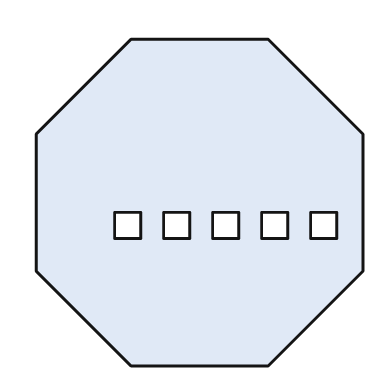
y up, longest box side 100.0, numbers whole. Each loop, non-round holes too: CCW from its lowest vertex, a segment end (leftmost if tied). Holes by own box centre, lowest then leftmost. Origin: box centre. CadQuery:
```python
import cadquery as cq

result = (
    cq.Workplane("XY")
    .moveTo(-21.0, -50.0)
    .lineTo(21.0, -50.0)
    .lineTo(50.0, -21.0)
    .lineTo(50.0, 21.0)
    .lineTo(21.0, 50.0)
    .lineTo(-21.0, 50.0)
    .lineTo(-50.0, 21.0)
    .lineTo(-50.0, -21.0)
    .close()
    .moveTo(-26.0, -11.0)
    .lineTo(-18.0, -11.0)
    .lineTo(-18.0, -3.0)
    .lineTo(-26.0, -3.0)
    .close()
    .moveTo(-11.0, -11.0)
    .lineTo(-3.0, -11.0)
    .lineTo(-3.0, -3.0)
    .lineTo(-11.0, -3.0)
    .close()
    .moveTo(4.0, -11.0)
    .lineTo(12.0, -11.0)
    .lineTo(12.0, -3.0)
    .lineTo(4.0, -3.0)
    .close()
    .moveTo(19.0, -11.0)
    .lineTo(27.0, -11.0)
    .lineTo(27.0, -3.0)
    .lineTo(19.0, -3.0)
    .close()
    .moveTo(34.0, -11.0)
    .lineTo(42.0, -11.0)
    .lineTo(42.0, -3.0)
    .lineTo(34.0, -3.0)
    .close()
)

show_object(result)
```